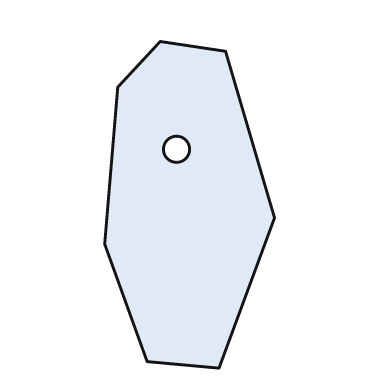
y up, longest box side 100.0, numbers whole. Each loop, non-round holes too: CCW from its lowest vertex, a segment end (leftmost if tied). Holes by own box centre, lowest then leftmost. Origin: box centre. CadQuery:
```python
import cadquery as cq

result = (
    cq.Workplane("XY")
    .moveTo(9.0, -50.0)
    .lineTo(26.0, -4.0)
    .lineTo(11.0, 47.0)
    .lineTo(-9.0, 50.0)
    .lineTo(-22.0, 36.0)
    .lineTo(-26.0, -12.0)
    .lineTo(-13.0, -48.0)
    .close()
    .moveTo(-4.0, 17.0)
    .circle(4.0)
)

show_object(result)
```